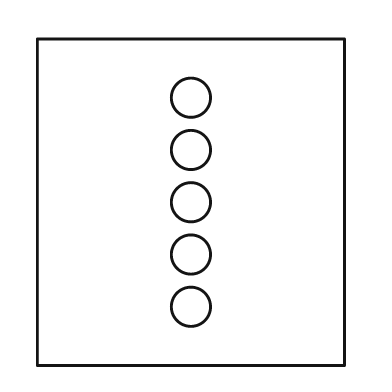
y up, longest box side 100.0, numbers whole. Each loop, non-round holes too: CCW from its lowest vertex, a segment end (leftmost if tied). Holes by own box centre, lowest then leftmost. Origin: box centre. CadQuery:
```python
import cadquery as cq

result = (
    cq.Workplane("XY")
    .moveTo(-47.0, -50.0)
    .lineTo(47.0, -50.0)
    .lineTo(47.0, 50.0)
    .lineTo(-47.0, 50.0)
    .close()
    .moveTo(0.0, -32.0)
    .circle(6.0)
    .moveTo(0.0, -16.0)
    .circle(6.0)
    .moveTo(0.0, 0.0)
    .circle(6.0)
    .moveTo(0.0, 16.0)
    .circle(6.0)
    .moveTo(0.0, 32.0)
    .circle(6.0)
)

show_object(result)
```